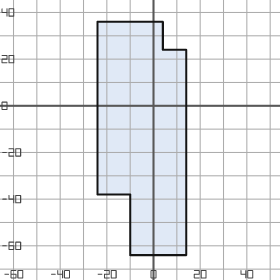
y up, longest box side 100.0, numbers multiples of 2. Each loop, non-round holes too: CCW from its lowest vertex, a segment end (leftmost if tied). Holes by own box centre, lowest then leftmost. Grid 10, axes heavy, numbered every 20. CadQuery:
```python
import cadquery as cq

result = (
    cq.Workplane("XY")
    .moveTo(-10.0, -64.0)
    .lineTo(14.0, -64.0)
    .lineTo(14.0, 24.0)
    .lineTo(4.0, 24.0)
    .lineTo(4.0, 36.0)
    .lineTo(-24.0, 36.0)
    .lineTo(-24.0, -38.0)
    .lineTo(-10.0, -38.0)
    .close()
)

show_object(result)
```